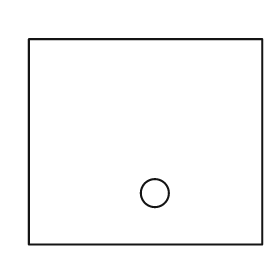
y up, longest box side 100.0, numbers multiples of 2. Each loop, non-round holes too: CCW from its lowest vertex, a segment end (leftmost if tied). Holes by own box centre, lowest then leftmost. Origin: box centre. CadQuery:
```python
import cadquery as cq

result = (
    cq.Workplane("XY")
    .moveTo(-50.0, -44.0)
    .lineTo(50.0, -44.0)
    .lineTo(50.0, 44.0)
    .lineTo(-50.0, 44.0)
    .close()
    .moveTo(4.0, -22.0)
    .circle(6.0)
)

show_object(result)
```